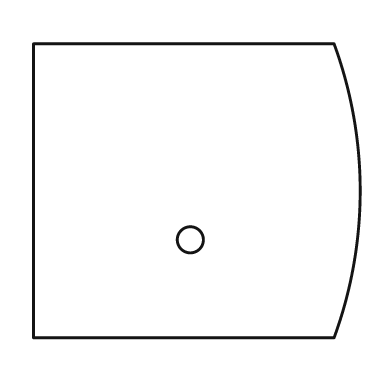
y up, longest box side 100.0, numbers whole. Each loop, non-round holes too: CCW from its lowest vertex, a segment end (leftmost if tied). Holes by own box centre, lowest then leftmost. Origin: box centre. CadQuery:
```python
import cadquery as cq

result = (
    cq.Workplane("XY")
    .moveTo(-50.0, -45.0)
    .lineTo(42.0, -45.0)
    .threePointArc((50.0, 0.0), (42.0, 45.0))
    .lineTo(-50.0, 45.0)
    .close()
    .moveTo(-2.0, -15.0)
    .circle(4.0)
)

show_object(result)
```